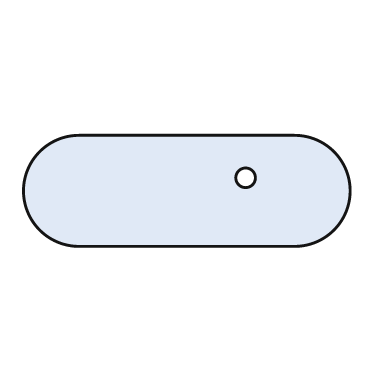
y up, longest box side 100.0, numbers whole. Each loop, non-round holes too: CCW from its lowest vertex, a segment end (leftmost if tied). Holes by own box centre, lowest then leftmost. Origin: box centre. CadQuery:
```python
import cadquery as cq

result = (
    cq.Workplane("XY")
    .moveTo(-33.0, -17.0)
    .lineTo(33.0, -17.0)
    .threePointArc((50.0, 0.0), (33.0, 17.0))
    .lineTo(-33.0, 17.0)
    .threePointArc((-50.0, 0.0), (-33.0, -17.0))
    .close()
    .moveTo(18.0, 4.0)
    .circle(3.0)
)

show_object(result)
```